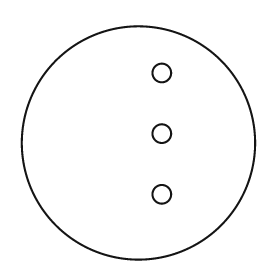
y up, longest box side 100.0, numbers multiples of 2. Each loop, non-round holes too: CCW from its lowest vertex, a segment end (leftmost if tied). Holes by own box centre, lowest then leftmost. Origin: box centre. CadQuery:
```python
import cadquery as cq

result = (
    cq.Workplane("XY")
    .moveTo(0.0, 0.0)
    .circle(50.0)
    .moveTo(10.0, -22.0)
    .circle(4.0)
    .moveTo(10.0, 4.0)
    .circle(4.0)
    .moveTo(10.0, 30.0)
    .circle(4.0)
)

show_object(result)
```